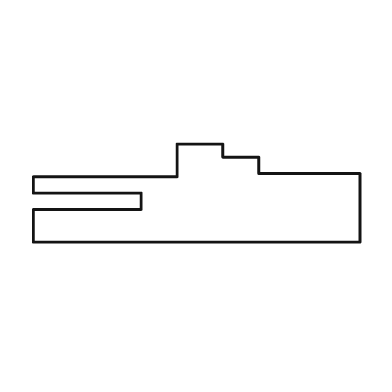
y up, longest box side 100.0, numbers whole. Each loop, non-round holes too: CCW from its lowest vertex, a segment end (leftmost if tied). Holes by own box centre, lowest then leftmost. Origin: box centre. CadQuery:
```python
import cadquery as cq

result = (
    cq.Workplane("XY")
    .moveTo(-50.0, -15.0)
    .lineTo(50.0, -15.0)
    .lineTo(50.0, 6.0)
    .lineTo(19.0, 6.0)
    .lineTo(19.0, 11.0)
    .lineTo(8.0, 11.0)
    .lineTo(8.0, 15.0)
    .lineTo(-6.0, 15.0)
    .lineTo(-6.0, 5.0)
    .lineTo(-50.0, 5.0)
    .lineTo(-50.0, 0.0)
    .lineTo(-17.0, 0.0)
    .lineTo(-17.0, -5.0)
    .lineTo(-50.0, -5.0)
    .close()
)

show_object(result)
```